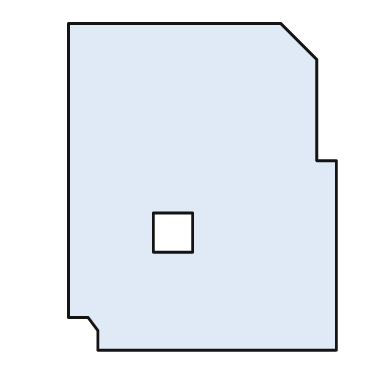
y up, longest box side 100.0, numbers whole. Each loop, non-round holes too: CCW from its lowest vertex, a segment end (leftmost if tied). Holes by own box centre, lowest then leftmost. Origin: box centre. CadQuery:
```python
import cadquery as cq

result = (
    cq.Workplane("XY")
    .moveTo(-32.0, -50.0)
    .lineTo(41.0, -50.0)
    .lineTo(41.0, 8.0)
    .lineTo(35.0, 8.0)
    .lineTo(35.0, 39.0)
    .lineTo(24.0, 50.0)
    .lineTo(-41.0, 50.0)
    .lineTo(-41.0, -40.0)
    .lineTo(-35.0, -40.0)
    .lineTo(-32.0, -44.0)
    .close()
    .moveTo(-15.0, -20.0)
    .lineTo(-3.0, -20.0)
    .lineTo(-3.0, -8.0)
    .lineTo(-15.0, -8.0)
    .close()
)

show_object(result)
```